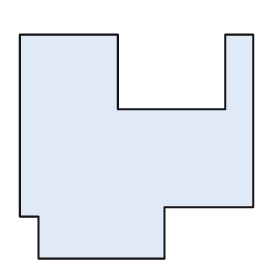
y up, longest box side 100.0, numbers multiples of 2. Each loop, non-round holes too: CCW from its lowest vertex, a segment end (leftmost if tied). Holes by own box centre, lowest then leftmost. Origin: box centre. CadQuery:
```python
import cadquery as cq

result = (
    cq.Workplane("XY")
    .moveTo(-42.0, -48.0)
    .lineTo(12.0, -48.0)
    .lineTo(12.0, -26.0)
    .lineTo(50.0, -26.0)
    .lineTo(50.0, 48.0)
    .lineTo(38.0, 48.0)
    .lineTo(38.0, 16.0)
    .lineTo(-8.0, 16.0)
    .lineTo(-8.0, 48.0)
    .lineTo(-50.0, 48.0)
    .lineTo(-50.0, -30.0)
    .lineTo(-42.0, -30.0)
    .close()
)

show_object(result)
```